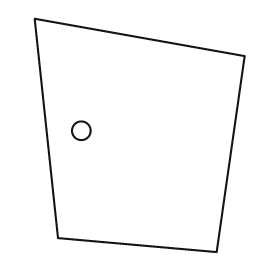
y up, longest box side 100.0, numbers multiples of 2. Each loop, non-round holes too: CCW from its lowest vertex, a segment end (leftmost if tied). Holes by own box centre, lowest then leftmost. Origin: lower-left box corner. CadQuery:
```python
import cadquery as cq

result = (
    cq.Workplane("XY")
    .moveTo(78.0, 0.0)
    .lineTo(90.0, 84.0)
    .lineTo(0.0, 100.0)
    .lineTo(10.0, 6.0)
    .close()
    .moveTo(20.0, 52.0)
    .circle(4.0)
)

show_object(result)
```